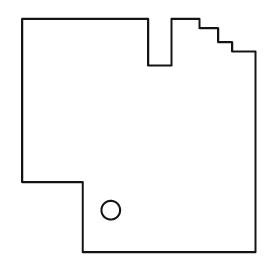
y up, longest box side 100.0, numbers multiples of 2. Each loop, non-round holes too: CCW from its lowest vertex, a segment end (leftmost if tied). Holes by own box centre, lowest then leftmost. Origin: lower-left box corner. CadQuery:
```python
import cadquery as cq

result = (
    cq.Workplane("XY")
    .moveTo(26.0, 0.0)
    .lineTo(100.0, 0.0)
    .lineTo(100.0, 86.0)
    .lineTo(90.0, 86.0)
    .lineTo(90.0, 90.0)
    .lineTo(84.0, 90.0)
    .lineTo(84.0, 96.0)
    .lineTo(76.0, 96.0)
    .lineTo(76.0, 100.0)
    .lineTo(64.0, 100.0)
    .lineTo(64.0, 80.0)
    .lineTo(54.0, 80.0)
    .lineTo(54.0, 100.0)
    .lineTo(0.0, 100.0)
    .lineTo(0.0, 30.0)
    .lineTo(26.0, 30.0)
    .close()
    .moveTo(38.0, 18.0)
    .circle(4.0)
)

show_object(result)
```